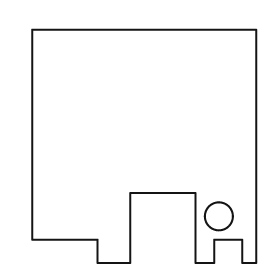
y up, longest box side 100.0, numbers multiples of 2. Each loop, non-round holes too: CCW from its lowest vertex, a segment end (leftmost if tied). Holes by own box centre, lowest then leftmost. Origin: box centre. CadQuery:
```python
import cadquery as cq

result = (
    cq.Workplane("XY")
    .moveTo(-20.0, -50.0)
    .lineTo(-6.0, -50.0)
    .lineTo(-6.0, -20.0)
    .lineTo(22.0, -20.0)
    .lineTo(22.0, -50.0)
    .lineTo(30.0, -50.0)
    .lineTo(30.0, -40.0)
    .lineTo(42.0, -40.0)
    .lineTo(42.0, -50.0)
    .lineTo(48.0, -50.0)
    .lineTo(48.0, 50.0)
    .lineTo(-48.0, 50.0)
    .lineTo(-48.0, -40.0)
    .lineTo(-20.0, -40.0)
    .close()
    .moveTo(32.0, -30.0)
    .circle(6.0)
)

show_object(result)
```